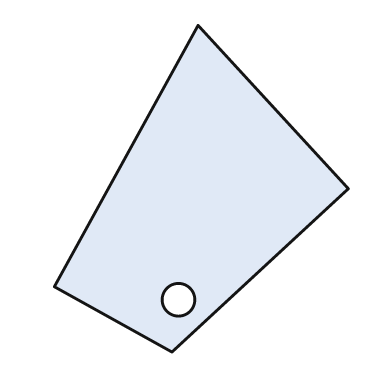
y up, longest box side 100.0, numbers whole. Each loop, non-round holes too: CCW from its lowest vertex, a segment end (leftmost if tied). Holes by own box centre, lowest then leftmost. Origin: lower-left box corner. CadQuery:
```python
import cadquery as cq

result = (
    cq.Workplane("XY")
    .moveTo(36.0, 0.0)
    .lineTo(90.0, 50.0)
    .lineTo(44.0, 100.0)
    .lineTo(0.0, 20.0)
    .close()
    .moveTo(38.0, 16.0)
    .circle(5.0)
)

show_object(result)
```